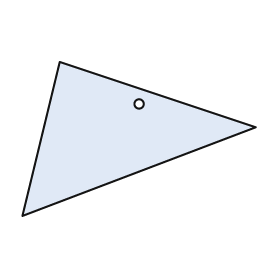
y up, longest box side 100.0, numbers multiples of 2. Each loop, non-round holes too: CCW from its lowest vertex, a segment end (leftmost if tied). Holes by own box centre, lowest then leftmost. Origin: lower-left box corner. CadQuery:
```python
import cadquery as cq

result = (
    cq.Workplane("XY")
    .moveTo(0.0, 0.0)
    .lineTo(100.0, 38.0)
    .lineTo(16.0, 66.0)
    .close()
    .moveTo(50.0, 48.0)
    .circle(2.0)
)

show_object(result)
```